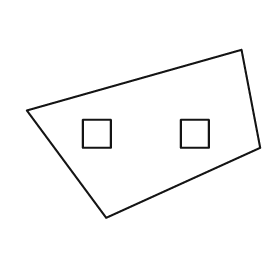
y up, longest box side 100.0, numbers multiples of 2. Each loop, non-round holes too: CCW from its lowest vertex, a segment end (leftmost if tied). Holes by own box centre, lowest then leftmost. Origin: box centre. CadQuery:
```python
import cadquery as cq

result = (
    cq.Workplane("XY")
    .moveTo(-16.0, -36.0)
    .lineTo(50.0, -6.0)
    .lineTo(42.0, 36.0)
    .lineTo(-50.0, 10.0)
    .close()
    .moveTo(-26.0, -6.0)
    .lineTo(-14.0, -6.0)
    .lineTo(-14.0, 6.0)
    .lineTo(-26.0, 6.0)
    .close()
    .moveTo(16.0, -6.0)
    .lineTo(28.0, -6.0)
    .lineTo(28.0, 6.0)
    .lineTo(16.0, 6.0)
    .close()
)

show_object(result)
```